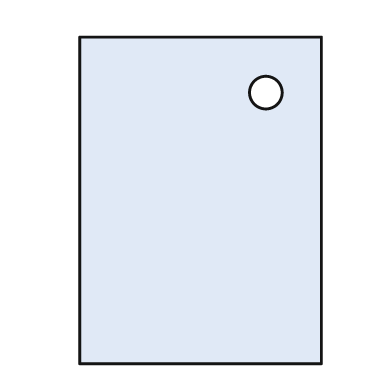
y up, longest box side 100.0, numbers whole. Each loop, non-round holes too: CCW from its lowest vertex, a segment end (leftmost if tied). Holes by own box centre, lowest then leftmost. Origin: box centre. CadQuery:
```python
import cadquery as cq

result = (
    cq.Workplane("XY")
    .moveTo(-37.0, -50.0)
    .lineTo(37.0, -50.0)
    .lineTo(37.0, 50.0)
    .lineTo(-37.0, 50.0)
    .close()
    .moveTo(20.0, 33.0)
    .circle(5.0)
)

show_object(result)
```